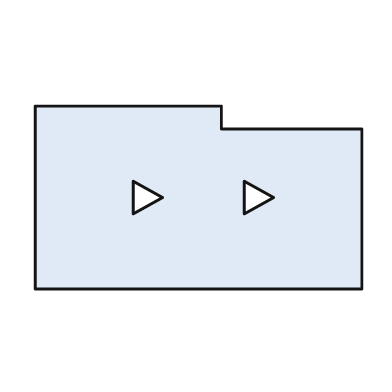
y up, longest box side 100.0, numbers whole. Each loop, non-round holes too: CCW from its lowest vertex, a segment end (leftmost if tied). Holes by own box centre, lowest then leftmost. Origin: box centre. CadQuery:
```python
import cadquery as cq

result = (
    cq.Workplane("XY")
    .moveTo(-50.0, -28.0)
    .lineTo(50.0, -28.0)
    .lineTo(50.0, 21.0)
    .lineTo(7.0, 21.0)
    .lineTo(7.0, 28.0)
    .lineTo(-50.0, 28.0)
    .close()
    .moveTo(-20.0, -5.0)
    .lineTo(-11.0, 0.0)
    .lineTo(-20.0, 5.0)
    .close()
    .moveTo(14.0, -5.0)
    .lineTo(23.0, 0.0)
    .lineTo(14.0, 5.0)
    .close()
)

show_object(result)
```